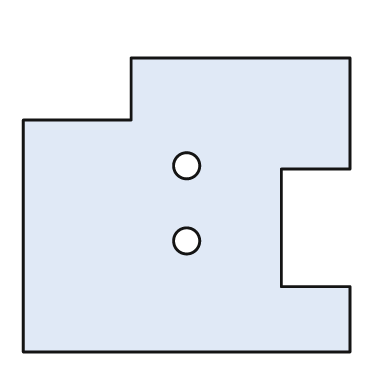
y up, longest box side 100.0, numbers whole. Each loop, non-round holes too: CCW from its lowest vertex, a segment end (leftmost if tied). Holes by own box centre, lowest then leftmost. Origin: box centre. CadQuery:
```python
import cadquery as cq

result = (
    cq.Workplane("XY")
    .moveTo(-50.0, -45.0)
    .lineTo(50.0, -45.0)
    .lineTo(50.0, -25.0)
    .lineTo(29.0, -25.0)
    .lineTo(29.0, 11.0)
    .lineTo(50.0, 11.0)
    .lineTo(50.0, 45.0)
    .lineTo(-17.0, 45.0)
    .lineTo(-17.0, 26.0)
    .lineTo(-50.0, 26.0)
    .close()
    .moveTo(0.0, -11.0)
    .circle(4.0)
    .moveTo(0.0, 12.0)
    .circle(4.0)
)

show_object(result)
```